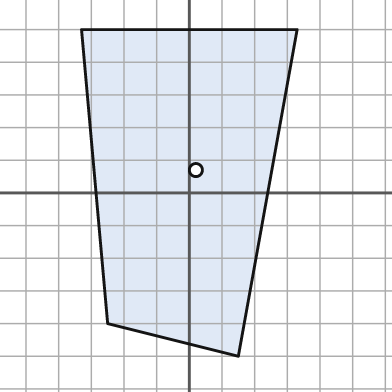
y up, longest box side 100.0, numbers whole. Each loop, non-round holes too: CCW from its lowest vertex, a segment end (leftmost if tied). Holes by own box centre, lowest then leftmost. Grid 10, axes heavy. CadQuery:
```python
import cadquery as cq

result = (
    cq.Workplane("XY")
    .moveTo(15.0, -50.0)
    .lineTo(33.0, 50.0)
    .lineTo(-33.0, 50.0)
    .lineTo(-25.0, -40.0)
    .close()
    .moveTo(2.0, 7.0)
    .circle(2.0)
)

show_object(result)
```